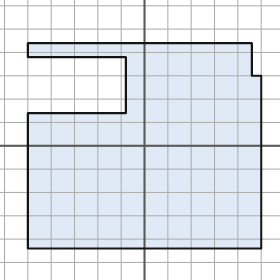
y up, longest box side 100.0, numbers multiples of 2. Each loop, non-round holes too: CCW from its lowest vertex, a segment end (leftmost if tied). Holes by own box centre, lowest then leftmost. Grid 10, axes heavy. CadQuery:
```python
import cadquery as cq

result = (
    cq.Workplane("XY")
    .moveTo(-50.0, -44.0)
    .lineTo(50.0, -44.0)
    .lineTo(50.0, 30.0)
    .lineTo(46.0, 30.0)
    .lineTo(46.0, 44.0)
    .lineTo(-50.0, 44.0)
    .lineTo(-50.0, 38.0)
    .lineTo(-8.0, 38.0)
    .lineTo(-8.0, 14.0)
    .lineTo(-50.0, 14.0)
    .close()
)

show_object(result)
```